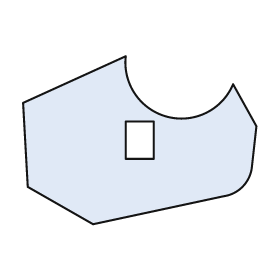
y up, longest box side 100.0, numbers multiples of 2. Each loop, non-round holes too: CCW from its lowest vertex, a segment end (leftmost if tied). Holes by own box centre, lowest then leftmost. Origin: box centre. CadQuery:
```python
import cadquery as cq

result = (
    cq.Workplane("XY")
    .moveTo(-20.0, -36.0)
    .lineTo(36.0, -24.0)
    .threePointArc((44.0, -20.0), (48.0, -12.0))
    .lineTo(50.0, 6.0)
    .lineTo(40.0, 24.0)
    .threePointArc((12.0, 10.0), (-6.0, 36.0))
    .lineTo(-50.0, 16.0)
    .lineTo(-48.0, -20.0)
    .close()
    .moveTo(-6.0, -8.0)
    .lineTo(6.0, -8.0)
    .lineTo(6.0, 8.0)
    .lineTo(-6.0, 8.0)
    .close()
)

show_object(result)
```